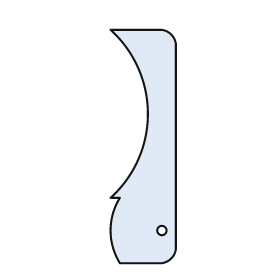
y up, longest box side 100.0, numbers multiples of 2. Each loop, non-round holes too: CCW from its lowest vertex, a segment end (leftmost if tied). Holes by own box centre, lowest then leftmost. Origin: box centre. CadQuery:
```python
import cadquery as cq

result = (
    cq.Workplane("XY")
    .moveTo(-10.0, -50.0)
    .lineTo(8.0, -50.0)
    .threePointArc((12.0, -48.0), (14.0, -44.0))
    .lineTo(14.0, 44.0)
    .threePointArc((12.0, 48.0), (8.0, 50.0))
    .lineTo(-14.0, 50.0)
    .threePointArc((2.0, 14.0), (-14.0, -22.0))
    .lineTo(-10.0, -22.0)
    .threePointArc((-14.0, -36.0), (-10.0, -50.0))
    .close()
    .moveTo(8.0, -36.0)
    .circle(2.0)
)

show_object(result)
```